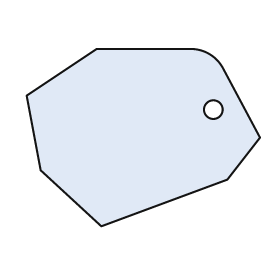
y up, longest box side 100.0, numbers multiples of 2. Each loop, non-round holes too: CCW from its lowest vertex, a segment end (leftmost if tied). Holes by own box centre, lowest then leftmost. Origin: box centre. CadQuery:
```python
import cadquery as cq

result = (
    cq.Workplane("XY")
    .moveTo(-18.0, -38.0)
    .lineTo(36.0, -18.0)
    .lineTo(50.0, 0.0)
    .lineTo(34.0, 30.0)
    .threePointArc((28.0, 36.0), (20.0, 38.0))
    .lineTo(-20.0, 38.0)
    .lineTo(-50.0, 18.0)
    .lineTo(-44.0, -14.0)
    .close()
    .moveTo(30.0, 12.0)
    .circle(4.0)
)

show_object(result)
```